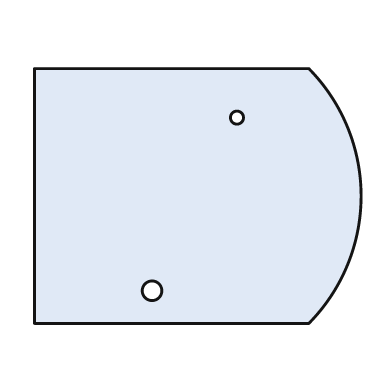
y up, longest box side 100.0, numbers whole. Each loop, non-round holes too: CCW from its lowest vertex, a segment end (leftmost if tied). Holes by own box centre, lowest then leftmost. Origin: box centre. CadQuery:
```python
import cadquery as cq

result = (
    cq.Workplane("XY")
    .moveTo(-50.0, -39.0)
    .lineTo(34.0, -39.0)
    .threePointArc((50.0, 0.0), (34.0, 39.0))
    .lineTo(-50.0, 39.0)
    .close()
    .moveTo(-14.0, -29.0)
    .circle(3.0)
    .moveTo(12.0, 24.0)
    .circle(2.0)
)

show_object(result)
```